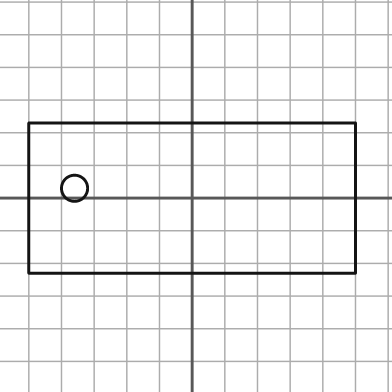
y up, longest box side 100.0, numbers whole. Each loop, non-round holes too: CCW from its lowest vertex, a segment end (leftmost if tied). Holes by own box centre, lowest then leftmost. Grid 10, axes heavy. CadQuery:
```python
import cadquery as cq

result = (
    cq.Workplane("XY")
    .moveTo(-50.0, -23.0)
    .lineTo(50.0, -23.0)
    .lineTo(50.0, 23.0)
    .lineTo(-50.0, 23.0)
    .close()
    .moveTo(-36.0, 3.0)
    .circle(4.0)
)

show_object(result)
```